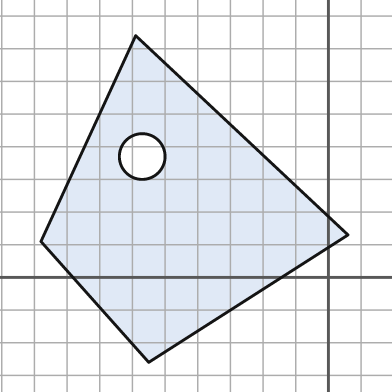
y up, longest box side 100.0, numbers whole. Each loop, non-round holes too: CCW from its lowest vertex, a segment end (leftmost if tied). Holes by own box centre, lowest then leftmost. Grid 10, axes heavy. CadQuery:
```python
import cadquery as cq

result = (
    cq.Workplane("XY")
    .moveTo(-55.0, -26.0)
    .lineTo(6.0, 13.0)
    .lineTo(-59.0, 74.0)
    .lineTo(-88.0, 11.0)
    .close()
    .moveTo(-57.0, 37.0)
    .circle(7.0)
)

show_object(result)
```